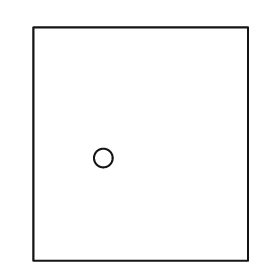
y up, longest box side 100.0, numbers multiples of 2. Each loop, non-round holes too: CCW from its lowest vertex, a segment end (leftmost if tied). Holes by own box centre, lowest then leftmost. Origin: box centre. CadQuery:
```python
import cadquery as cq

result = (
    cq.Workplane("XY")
    .moveTo(-46.0, -50.0)
    .lineTo(46.0, -50.0)
    .lineTo(46.0, 50.0)
    .lineTo(-46.0, 50.0)
    .close()
    .moveTo(-16.0, -6.0)
    .circle(4.0)
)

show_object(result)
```